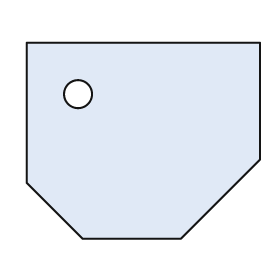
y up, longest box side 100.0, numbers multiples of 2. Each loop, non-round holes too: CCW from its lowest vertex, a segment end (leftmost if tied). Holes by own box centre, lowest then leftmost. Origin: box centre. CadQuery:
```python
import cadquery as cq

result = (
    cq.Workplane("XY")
    .moveTo(-26.0, -42.0)
    .lineTo(16.0, -42.0)
    .lineTo(50.0, -8.0)
    .lineTo(50.0, 42.0)
    .lineTo(-50.0, 42.0)
    .lineTo(-50.0, -18.0)
    .close()
    .moveTo(-28.0, 20.0)
    .circle(6.0)
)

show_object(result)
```